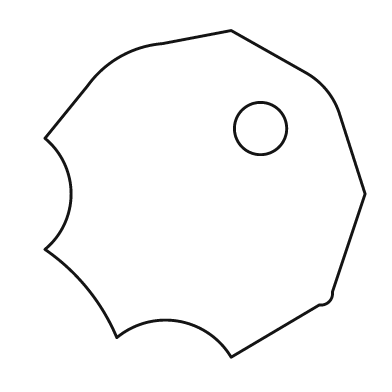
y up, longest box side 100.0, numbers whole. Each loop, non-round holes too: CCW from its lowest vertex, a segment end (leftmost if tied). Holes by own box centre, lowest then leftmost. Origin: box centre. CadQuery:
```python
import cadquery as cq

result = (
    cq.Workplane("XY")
    .moveTo(8.0, -50.0)
    .lineTo(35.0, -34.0)
    .threePointArc((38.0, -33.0), (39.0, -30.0))
    .lineTo(49.0, 0.0)
    .lineTo(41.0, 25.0)
    .threePointArc((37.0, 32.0), (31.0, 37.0))
    .lineTo(8.0, 50.0)
    .lineTo(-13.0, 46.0)
    .threePointArc((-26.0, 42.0), (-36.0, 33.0))
    .lineTo(-49.0, 17.0)
    .threePointArc((-41.0, 0.0), (-49.0, -17.0))
    .threePointArc((-36.0, -29.0), (-27.0, -44.0))
    .threePointArc((-8.0, -39.0), (8.0, -50.0))
    .close()
    .moveTo(17.0, 20.0)
    .circle(8.0)
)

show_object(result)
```